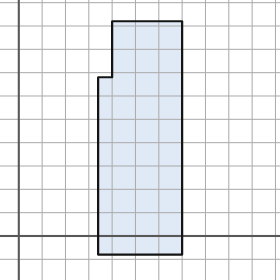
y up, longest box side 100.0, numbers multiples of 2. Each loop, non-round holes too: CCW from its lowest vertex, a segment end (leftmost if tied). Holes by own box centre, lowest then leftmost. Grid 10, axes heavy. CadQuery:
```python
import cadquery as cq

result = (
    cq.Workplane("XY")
    .moveTo(34.0, -8.0)
    .lineTo(70.0, -8.0)
    .lineTo(70.0, 92.0)
    .lineTo(40.0, 92.0)
    .lineTo(40.0, 68.0)
    .lineTo(34.0, 68.0)
    .close()
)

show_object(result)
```